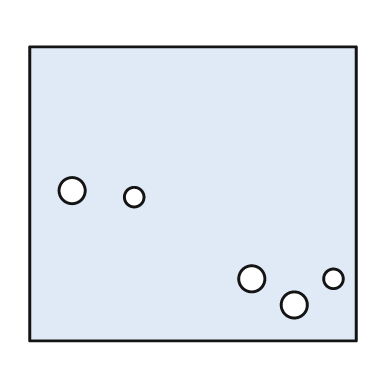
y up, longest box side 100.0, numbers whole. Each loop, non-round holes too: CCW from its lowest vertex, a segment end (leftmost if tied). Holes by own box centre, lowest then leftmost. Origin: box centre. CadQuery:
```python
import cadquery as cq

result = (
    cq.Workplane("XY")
    .moveTo(-50.0, -45.0)
    .lineTo(50.0, -45.0)
    .lineTo(50.0, 45.0)
    .lineTo(-50.0, 45.0)
    .close()
    .moveTo(31.0, -34.0)
    .circle(4.0)
    .moveTo(18.0, -26.0)
    .circle(4.0)
    .moveTo(43.0, -26.0)
    .circle(3.0)
    .moveTo(-18.0, -1.0)
    .circle(3.0)
    .moveTo(-37.0, 1.0)
    .circle(4.0)
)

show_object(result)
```